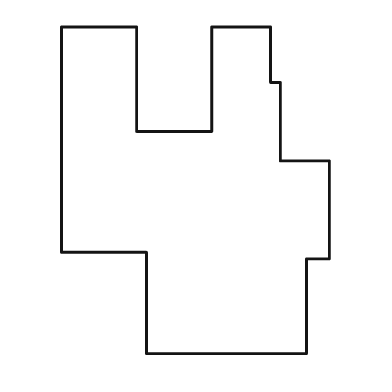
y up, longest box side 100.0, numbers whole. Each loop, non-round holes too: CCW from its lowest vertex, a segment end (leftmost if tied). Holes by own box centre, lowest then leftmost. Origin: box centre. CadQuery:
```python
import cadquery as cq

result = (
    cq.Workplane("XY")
    .moveTo(-15.0, -50.0)
    .lineTo(34.0, -50.0)
    .lineTo(34.0, -21.0)
    .lineTo(41.0, -21.0)
    .lineTo(41.0, 9.0)
    .lineTo(26.0, 9.0)
    .lineTo(26.0, 33.0)
    .lineTo(23.0, 33.0)
    .lineTo(23.0, 50.0)
    .lineTo(5.0, 50.0)
    .lineTo(5.0, 18.0)
    .lineTo(-18.0, 18.0)
    .lineTo(-18.0, 50.0)
    .lineTo(-41.0, 50.0)
    .lineTo(-41.0, -19.0)
    .lineTo(-15.0, -19.0)
    .close()
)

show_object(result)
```